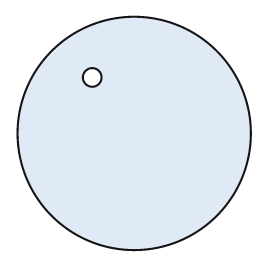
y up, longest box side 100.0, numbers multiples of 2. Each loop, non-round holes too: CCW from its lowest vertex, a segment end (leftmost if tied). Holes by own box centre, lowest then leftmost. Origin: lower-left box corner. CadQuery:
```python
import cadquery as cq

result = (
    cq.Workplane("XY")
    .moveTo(50.0, 50.0)
    .circle(50.0)
    .moveTo(32.0, 74.0)
    .circle(4.0)
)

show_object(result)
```